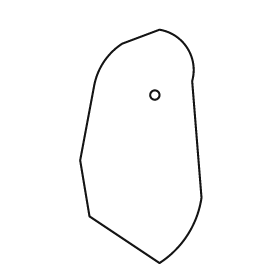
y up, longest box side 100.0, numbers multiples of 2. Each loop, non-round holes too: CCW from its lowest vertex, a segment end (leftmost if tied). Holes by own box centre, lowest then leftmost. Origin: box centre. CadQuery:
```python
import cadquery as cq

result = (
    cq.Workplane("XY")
    .moveTo(8.0, -50.0)
    .threePointArc((20.0, -38.0), (26.0, -22.0))
    .lineTo(22.0, 28.0)
    .threePointArc((20.0, 42.0), (8.0, 50.0))
    .lineTo(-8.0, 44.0)
    .threePointArc((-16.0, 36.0), (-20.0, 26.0))
    .lineTo(-26.0, -6.0)
    .lineTo(-22.0, -30.0)
    .close()
    .moveTo(6.0, 22.0)
    .circle(2.0)
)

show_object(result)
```